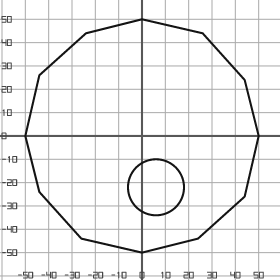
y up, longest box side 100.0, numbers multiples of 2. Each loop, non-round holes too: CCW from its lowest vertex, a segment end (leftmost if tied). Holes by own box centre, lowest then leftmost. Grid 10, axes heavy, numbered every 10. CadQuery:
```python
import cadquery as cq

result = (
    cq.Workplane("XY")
    .moveTo(0.0, -50.0)
    .lineTo(24.0, -44.0)
    .lineTo(44.0, -26.0)
    .lineTo(50.0, 0.0)
    .lineTo(44.0, 24.0)
    .lineTo(26.0, 44.0)
    .lineTo(0.0, 50.0)
    .lineTo(-24.0, 44.0)
    .lineTo(-44.0, 26.0)
    .lineTo(-50.0, 0.0)
    .lineTo(-44.0, -24.0)
    .lineTo(-26.0, -44.0)
    .close()
    .moveTo(6.0, -22.0)
    .circle(12.0)
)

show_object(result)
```